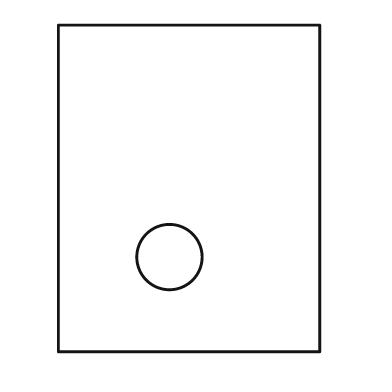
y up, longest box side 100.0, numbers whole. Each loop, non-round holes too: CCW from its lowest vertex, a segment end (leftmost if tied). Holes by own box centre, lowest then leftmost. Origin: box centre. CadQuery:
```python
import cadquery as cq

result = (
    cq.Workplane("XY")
    .moveTo(-40.0, -50.0)
    .lineTo(40.0, -50.0)
    .lineTo(40.0, 50.0)
    .lineTo(-40.0, 50.0)
    .close()
    .moveTo(-6.0, -21.0)
    .circle(10.0)
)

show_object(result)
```